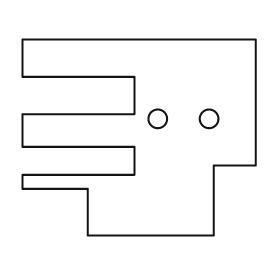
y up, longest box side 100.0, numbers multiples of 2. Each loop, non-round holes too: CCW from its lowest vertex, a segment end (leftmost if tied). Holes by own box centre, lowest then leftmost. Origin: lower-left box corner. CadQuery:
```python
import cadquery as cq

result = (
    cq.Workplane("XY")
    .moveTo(28.0, 0.0)
    .lineTo(82.0, 0.0)
    .lineTo(82.0, 30.0)
    .lineTo(100.0, 30.0)
    .lineTo(100.0, 84.0)
    .lineTo(0.0, 84.0)
    .lineTo(0.0, 68.0)
    .lineTo(48.0, 68.0)
    .lineTo(48.0, 52.0)
    .lineTo(0.0, 52.0)
    .lineTo(0.0, 38.0)
    .lineTo(48.0, 38.0)
    .lineTo(48.0, 26.0)
    .lineTo(0.0, 26.0)
    .lineTo(0.0, 20.0)
    .lineTo(28.0, 20.0)
    .close()
    .moveTo(58.0, 50.0)
    .circle(4.0)
    .moveTo(80.0, 50.0)
    .circle(4.0)
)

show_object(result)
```